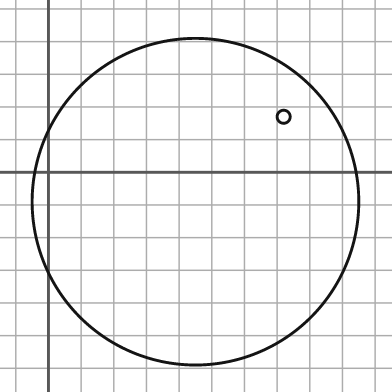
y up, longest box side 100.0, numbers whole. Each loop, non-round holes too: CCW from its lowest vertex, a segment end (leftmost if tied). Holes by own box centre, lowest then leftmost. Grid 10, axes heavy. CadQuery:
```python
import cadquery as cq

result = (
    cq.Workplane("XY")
    .moveTo(45.0, -9.0)
    .circle(50.0)
    .moveTo(72.0, 17.0)
    .circle(2.0)
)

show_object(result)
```